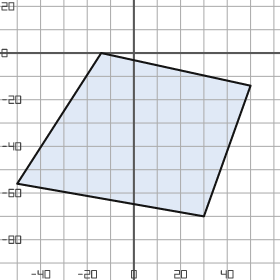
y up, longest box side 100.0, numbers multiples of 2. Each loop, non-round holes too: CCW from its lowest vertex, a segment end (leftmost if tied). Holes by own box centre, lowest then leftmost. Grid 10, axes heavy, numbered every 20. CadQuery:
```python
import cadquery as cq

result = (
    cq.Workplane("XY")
    .moveTo(30.0, -70.0)
    .lineTo(50.0, -14.0)
    .lineTo(-14.0, 0.0)
    .lineTo(-50.0, -56.0)
    .close()
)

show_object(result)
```